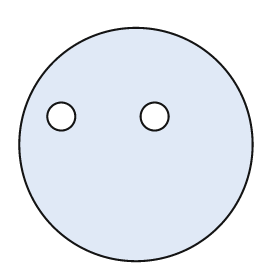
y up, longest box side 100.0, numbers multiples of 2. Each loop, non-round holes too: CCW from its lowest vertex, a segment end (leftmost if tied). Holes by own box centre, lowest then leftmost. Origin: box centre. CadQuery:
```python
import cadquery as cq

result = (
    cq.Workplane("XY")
    .moveTo(0.0, 0.0)
    .circle(50.0)
    .moveTo(-32.0, 12.0)
    .circle(6.0)
    .moveTo(8.0, 12.0)
    .circle(6.0)
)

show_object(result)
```